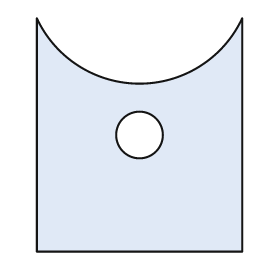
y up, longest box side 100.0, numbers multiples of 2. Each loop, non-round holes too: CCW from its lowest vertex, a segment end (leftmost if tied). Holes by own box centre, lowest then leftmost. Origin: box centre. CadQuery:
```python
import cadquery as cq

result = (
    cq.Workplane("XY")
    .moveTo(-44.0, -50.0)
    .lineTo(44.0, -50.0)
    .lineTo(44.0, 50.0)
    .threePointArc((0.0, 22.0), (-44.0, 50.0))
    .close()
    .moveTo(0.0, 0.0)
    .circle(10.0)
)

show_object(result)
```